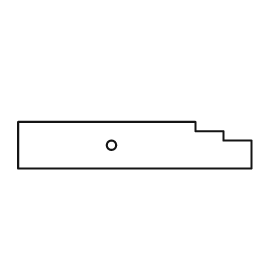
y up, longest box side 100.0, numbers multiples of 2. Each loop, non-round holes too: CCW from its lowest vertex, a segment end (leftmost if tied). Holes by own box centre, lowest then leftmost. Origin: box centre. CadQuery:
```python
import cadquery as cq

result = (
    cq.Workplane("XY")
    .moveTo(-50.0, -10.0)
    .lineTo(50.0, -10.0)
    .lineTo(50.0, 2.0)
    .lineTo(38.0, 2.0)
    .lineTo(38.0, 6.0)
    .lineTo(26.0, 6.0)
    .lineTo(26.0, 10.0)
    .lineTo(-50.0, 10.0)
    .close()
    .moveTo(-10.0, 0.0)
    .circle(2.0)
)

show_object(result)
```